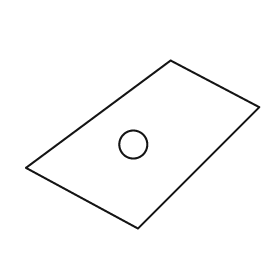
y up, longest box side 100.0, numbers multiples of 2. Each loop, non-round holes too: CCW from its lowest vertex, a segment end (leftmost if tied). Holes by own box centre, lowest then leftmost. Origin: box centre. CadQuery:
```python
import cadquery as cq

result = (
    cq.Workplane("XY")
    .moveTo(-2.0, -36.0)
    .lineTo(50.0, 16.0)
    .lineTo(12.0, 36.0)
    .lineTo(-50.0, -10.0)
    .close()
    .moveTo(-4.0, 0.0)
    .circle(6.0)
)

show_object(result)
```